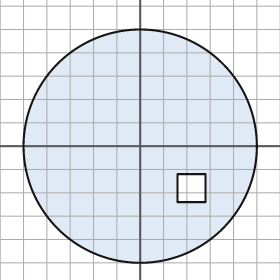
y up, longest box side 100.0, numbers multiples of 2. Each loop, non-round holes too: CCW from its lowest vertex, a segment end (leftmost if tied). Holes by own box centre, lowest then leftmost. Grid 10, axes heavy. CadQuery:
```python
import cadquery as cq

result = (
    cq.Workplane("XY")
    .moveTo(0.0, 0.0)
    .circle(50.0)
    .moveTo(16.0, -24.0)
    .lineTo(28.0, -24.0)
    .lineTo(28.0, -12.0)
    .lineTo(16.0, -12.0)
    .close()
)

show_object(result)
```